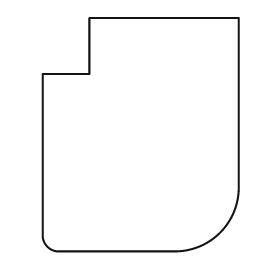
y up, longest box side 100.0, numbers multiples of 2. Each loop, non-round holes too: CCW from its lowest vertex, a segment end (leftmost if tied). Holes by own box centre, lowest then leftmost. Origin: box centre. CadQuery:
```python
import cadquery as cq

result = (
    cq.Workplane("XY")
    .moveTo(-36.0, -50.0)
    .lineTo(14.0, -50.0)
    .threePointArc((34.0, -42.0), (42.0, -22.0))
    .lineTo(42.0, 50.0)
    .lineTo(-22.0, 50.0)
    .lineTo(-22.0, 26.0)
    .lineTo(-42.0, 26.0)
    .lineTo(-42.0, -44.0)
    .threePointArc((-40.0, -48.0), (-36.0, -50.0))
    .close()
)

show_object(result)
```